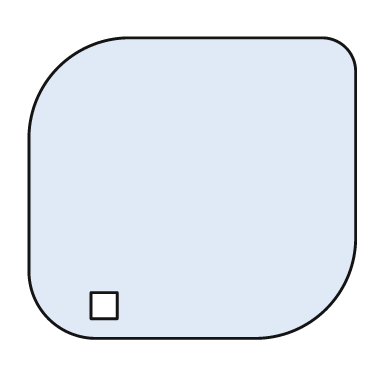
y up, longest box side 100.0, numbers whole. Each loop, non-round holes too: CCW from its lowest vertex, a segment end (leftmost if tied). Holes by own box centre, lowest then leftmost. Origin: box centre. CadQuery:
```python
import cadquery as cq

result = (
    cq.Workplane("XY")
    .moveTo(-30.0, -46.0)
    .lineTo(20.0, -46.0)
    .threePointArc((41.0, -37.0), (50.0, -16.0))
    .lineTo(50.0, 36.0)
    .threePointArc((47.0, 43.0), (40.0, 46.0))
    .lineTo(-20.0, 46.0)
    .threePointArc((-41.0, 37.0), (-50.0, 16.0))
    .lineTo(-50.0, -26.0)
    .threePointArc((-44.0, -40.0), (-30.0, -46.0))
    .close()
    .moveTo(-31.0, -40.0)
    .lineTo(-23.0, -40.0)
    .lineTo(-23.0, -32.0)
    .lineTo(-31.0, -32.0)
    .close()
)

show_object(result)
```